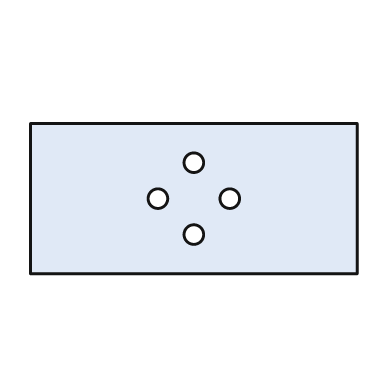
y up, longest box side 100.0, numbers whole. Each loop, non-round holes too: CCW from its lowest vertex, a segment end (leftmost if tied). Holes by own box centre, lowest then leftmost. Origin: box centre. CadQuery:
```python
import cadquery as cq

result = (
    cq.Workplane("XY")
    .moveTo(-50.0, -23.0)
    .lineTo(50.0, -23.0)
    .lineTo(50.0, 23.0)
    .lineTo(-50.0, 23.0)
    .close()
    .moveTo(0.0, -11.0)
    .circle(3.0)
    .moveTo(-11.0, 0.0)
    .circle(3.0)
    .moveTo(11.0, 0.0)
    .circle(3.0)
    .moveTo(0.0, 11.0)
    .circle(3.0)
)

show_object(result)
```